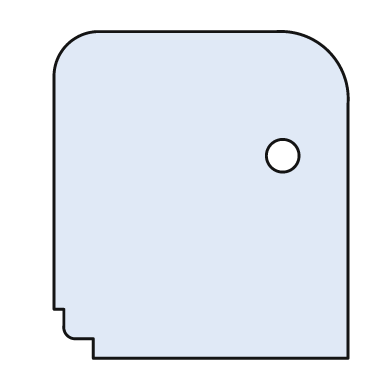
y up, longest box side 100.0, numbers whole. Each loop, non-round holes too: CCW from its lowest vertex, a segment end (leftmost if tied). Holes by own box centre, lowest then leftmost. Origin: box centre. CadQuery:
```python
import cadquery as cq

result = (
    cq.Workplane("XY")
    .moveTo(-33.0, -50.0)
    .lineTo(45.0, -50.0)
    .lineTo(45.0, 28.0)
    .threePointArc((39.0, 44.0), (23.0, 50.0))
    .lineTo(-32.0, 50.0)
    .threePointArc((-41.0, 46.0), (-45.0, 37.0))
    .lineTo(-45.0, -35.0)
    .lineTo(-42.0, -35.0)
    .lineTo(-42.0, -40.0)
    .threePointArc((-41.0, -43.0), (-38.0, -44.0))
    .lineTo(-33.0, -44.0)
    .close()
    .moveTo(25.0, 12.0)
    .circle(5.0)
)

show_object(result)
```